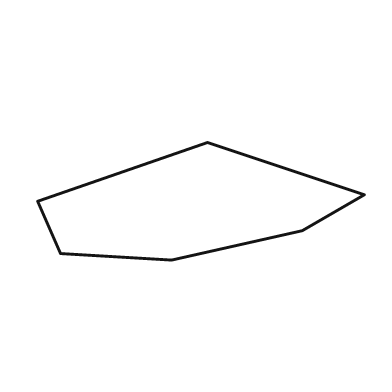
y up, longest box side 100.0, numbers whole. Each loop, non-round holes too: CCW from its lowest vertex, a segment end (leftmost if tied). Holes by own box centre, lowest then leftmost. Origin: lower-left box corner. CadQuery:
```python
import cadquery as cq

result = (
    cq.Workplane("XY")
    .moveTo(41.0, 0.0)
    .lineTo(81.0, 9.0)
    .lineTo(100.0, 20.0)
    .lineTo(52.0, 36.0)
    .lineTo(0.0, 18.0)
    .lineTo(7.0, 2.0)
    .close()
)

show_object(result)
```